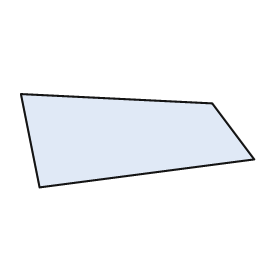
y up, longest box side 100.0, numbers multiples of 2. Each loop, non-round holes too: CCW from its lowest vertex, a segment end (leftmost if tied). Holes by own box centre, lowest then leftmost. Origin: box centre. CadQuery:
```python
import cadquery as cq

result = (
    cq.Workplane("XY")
    .moveTo(-42.0, -20.0)
    .lineTo(50.0, -8.0)
    .lineTo(32.0, 16.0)
    .lineTo(-50.0, 20.0)
    .close()
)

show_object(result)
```